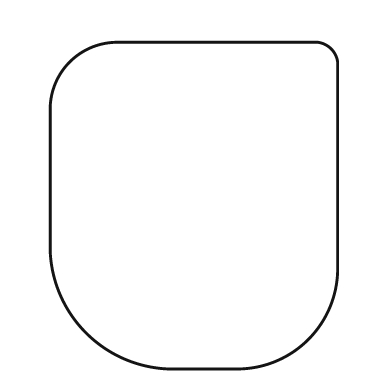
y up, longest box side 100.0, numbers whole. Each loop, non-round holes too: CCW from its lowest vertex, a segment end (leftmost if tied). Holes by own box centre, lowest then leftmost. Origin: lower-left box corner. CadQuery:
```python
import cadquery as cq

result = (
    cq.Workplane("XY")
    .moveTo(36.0, 0.0)
    .lineTo(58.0, 0.0)
    .threePointArc((79.0, 9.0), (88.0, 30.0))
    .lineTo(88.0, 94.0)
    .threePointArc((86.0, 98.0), (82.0, 100.0))
    .lineTo(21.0, 100.0)
    .threePointArc((6.0, 94.0), (0.0, 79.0))
    .lineTo(0.0, 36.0)
    .threePointArc((11.0, 11.0), (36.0, 0.0))
    .close()
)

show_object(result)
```